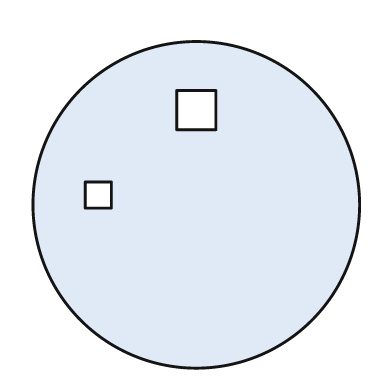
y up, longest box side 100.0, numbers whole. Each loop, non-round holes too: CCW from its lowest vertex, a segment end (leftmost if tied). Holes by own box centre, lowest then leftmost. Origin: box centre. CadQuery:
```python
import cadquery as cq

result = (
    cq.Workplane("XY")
    .moveTo(0.0, 0.0)
    .circle(50.0)
    .moveTo(-34.0, -1.0)
    .lineTo(-26.0, -1.0)
    .lineTo(-26.0, 7.0)
    .lineTo(-34.0, 7.0)
    .close()
    .moveTo(-6.0, 23.0)
    .lineTo(6.0, 23.0)
    .lineTo(6.0, 35.0)
    .lineTo(-6.0, 35.0)
    .close()
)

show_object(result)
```